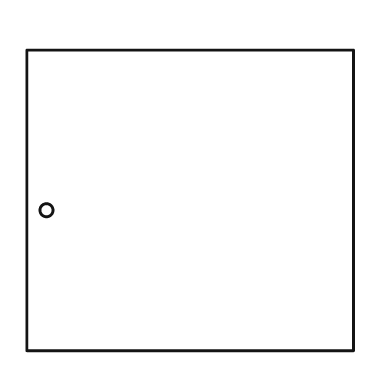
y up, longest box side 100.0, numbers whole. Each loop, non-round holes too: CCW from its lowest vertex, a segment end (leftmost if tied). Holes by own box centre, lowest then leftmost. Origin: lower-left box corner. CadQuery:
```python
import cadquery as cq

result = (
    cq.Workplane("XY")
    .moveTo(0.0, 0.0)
    .lineTo(100.0, 0.0)
    .lineTo(100.0, 92.0)
    .lineTo(0.0, 92.0)
    .close()
    .moveTo(6.0, 43.0)
    .circle(2.0)
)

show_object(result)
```